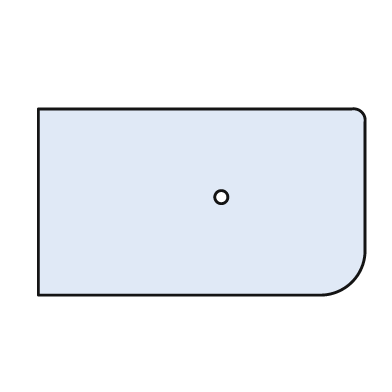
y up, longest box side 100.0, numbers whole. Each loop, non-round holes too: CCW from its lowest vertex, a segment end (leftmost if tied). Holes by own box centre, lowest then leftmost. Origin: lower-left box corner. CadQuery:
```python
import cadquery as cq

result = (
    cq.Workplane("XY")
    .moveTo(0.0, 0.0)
    .lineTo(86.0, 0.0)
    .threePointArc((96.0, 4.0), (100.0, 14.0))
    .lineTo(100.0, 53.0)
    .threePointArc((99.0, 56.0), (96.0, 57.0))
    .lineTo(0.0, 57.0)
    .close()
    .moveTo(56.0, 30.0)
    .circle(2.0)
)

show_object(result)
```